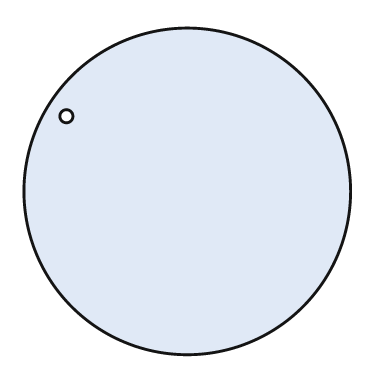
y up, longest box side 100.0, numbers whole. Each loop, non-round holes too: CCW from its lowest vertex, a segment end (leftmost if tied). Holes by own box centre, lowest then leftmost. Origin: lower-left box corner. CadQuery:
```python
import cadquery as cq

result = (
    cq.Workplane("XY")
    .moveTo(50.0, 50.0)
    .circle(50.0)
    .moveTo(13.0, 73.0)
    .circle(2.0)
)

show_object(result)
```